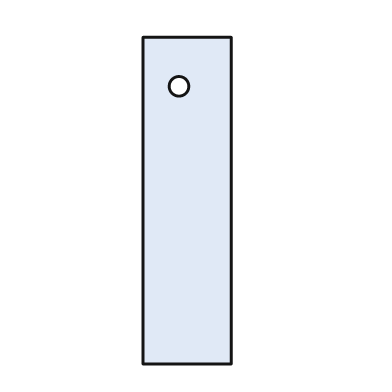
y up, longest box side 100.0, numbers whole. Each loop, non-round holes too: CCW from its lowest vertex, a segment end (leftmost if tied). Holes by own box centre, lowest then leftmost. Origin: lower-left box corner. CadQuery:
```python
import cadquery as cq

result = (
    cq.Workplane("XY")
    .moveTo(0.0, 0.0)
    .lineTo(27.0, 0.0)
    .lineTo(27.0, 100.0)
    .lineTo(0.0, 100.0)
    .close()
    .moveTo(11.0, 85.0)
    .circle(3.0)
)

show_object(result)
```